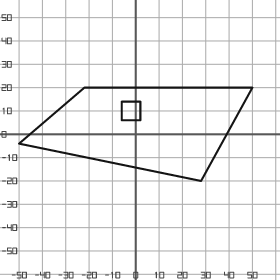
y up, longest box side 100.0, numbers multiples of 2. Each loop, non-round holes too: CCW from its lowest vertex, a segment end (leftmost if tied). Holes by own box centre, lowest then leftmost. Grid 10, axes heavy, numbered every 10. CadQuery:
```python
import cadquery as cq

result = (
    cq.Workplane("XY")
    .moveTo(28.0, -20.0)
    .lineTo(50.0, 20.0)
    .lineTo(-22.0, 20.0)
    .lineTo(-50.0, -4.0)
    .close()
    .moveTo(-6.0, 6.0)
    .lineTo(2.0, 6.0)
    .lineTo(2.0, 14.0)
    .lineTo(-6.0, 14.0)
    .close()
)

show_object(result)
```